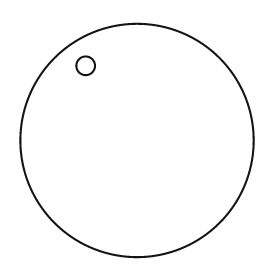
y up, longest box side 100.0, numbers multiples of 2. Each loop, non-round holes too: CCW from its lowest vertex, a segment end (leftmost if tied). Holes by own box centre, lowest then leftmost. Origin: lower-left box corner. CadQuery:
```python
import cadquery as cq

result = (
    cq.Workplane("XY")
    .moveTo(50.0, 50.0)
    .circle(50.0)
    .moveTo(28.0, 82.0)
    .circle(4.0)
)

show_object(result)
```